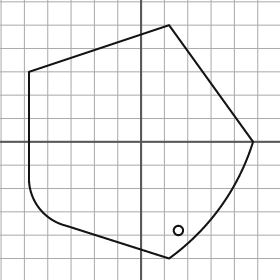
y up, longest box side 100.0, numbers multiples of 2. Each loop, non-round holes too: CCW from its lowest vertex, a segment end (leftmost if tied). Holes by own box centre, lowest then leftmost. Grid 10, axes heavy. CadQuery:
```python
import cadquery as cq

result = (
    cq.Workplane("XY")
    .moveTo(12.0, -50.0)
    .threePointArc((34.0, -28.0), (48.0, 0.0))
    .lineTo(12.0, 50.0)
    .lineTo(-48.0, 30.0)
    .lineTo(-48.0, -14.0)
    .threePointArc((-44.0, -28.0), (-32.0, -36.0))
    .close()
    .moveTo(16.0, -38.0)
    .circle(2.0)
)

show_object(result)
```